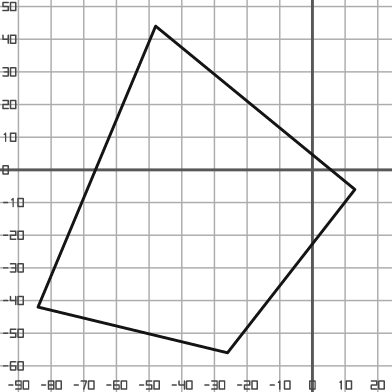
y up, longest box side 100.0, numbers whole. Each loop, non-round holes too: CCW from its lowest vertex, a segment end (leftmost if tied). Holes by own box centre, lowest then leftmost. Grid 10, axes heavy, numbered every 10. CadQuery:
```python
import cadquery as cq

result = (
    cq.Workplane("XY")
    .moveTo(-26.0, -56.0)
    .lineTo(13.0, -6.0)
    .lineTo(-48.0, 44.0)
    .lineTo(-84.0, -42.0)
    .close()
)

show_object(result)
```